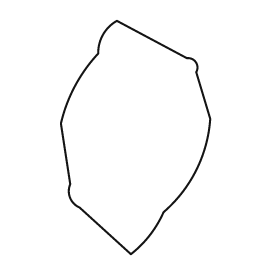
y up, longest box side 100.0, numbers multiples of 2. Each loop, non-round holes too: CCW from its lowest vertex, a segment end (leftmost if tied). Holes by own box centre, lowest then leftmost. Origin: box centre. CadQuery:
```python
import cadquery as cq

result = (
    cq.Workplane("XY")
    .moveTo(-2.0, -50.0)
    .threePointArc((6.0, -42.0), (12.0, -32.0))
    .threePointArc((26.0, -14.0), (32.0, 8.0))
    .lineTo(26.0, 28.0)
    .threePointArc((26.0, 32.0), (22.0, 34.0))
    .lineTo(-8.0, 50.0)
    .threePointArc((-14.0, 44.0), (-16.0, 36.0))
    .threePointArc((-26.0, 22.0), (-32.0, 6.0))
    .lineTo(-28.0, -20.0)
    .threePointArc((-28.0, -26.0), (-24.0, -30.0))
    .close()
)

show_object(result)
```